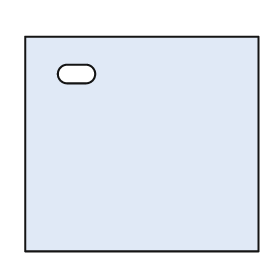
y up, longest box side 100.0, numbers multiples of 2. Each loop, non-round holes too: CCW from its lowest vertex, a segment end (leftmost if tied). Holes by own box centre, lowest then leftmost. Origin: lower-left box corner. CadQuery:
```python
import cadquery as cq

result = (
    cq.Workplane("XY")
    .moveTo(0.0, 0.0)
    .lineTo(100.0, 0.0)
    .lineTo(100.0, 92.0)
    .lineTo(0.0, 92.0)
    .close()
    .moveTo(18.0, 72.0)
    .lineTo(26.0, 72.0)
    .threePointArc((30.0, 76.0), (26.0, 80.0))
    .lineTo(18.0, 80.0)
    .threePointArc((14.0, 76.0), (18.0, 72.0))
    .close()
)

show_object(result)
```